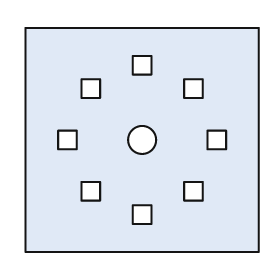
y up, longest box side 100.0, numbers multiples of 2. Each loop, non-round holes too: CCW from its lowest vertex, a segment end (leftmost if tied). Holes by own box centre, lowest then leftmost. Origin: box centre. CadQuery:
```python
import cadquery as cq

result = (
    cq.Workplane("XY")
    .moveTo(-50.0, -48.0)
    .lineTo(50.0, -48.0)
    .lineTo(50.0, 48.0)
    .lineTo(-50.0, 48.0)
    .close()
    .moveTo(-4.0, -36.0)
    .lineTo(4.0, -36.0)
    .lineTo(4.0, -28.0)
    .lineTo(-4.0, -28.0)
    .close()
    .moveTo(-26.0, -26.0)
    .lineTo(-18.0, -26.0)
    .lineTo(-18.0, -18.0)
    .lineTo(-26.0, -18.0)
    .close()
    .moveTo(18.0, -26.0)
    .lineTo(26.0, -26.0)
    .lineTo(26.0, -18.0)
    .lineTo(18.0, -18.0)
    .close()
    .moveTo(-36.0, -4.0)
    .lineTo(-28.0, -4.0)
    .lineTo(-28.0, 4.0)
    .lineTo(-36.0, 4.0)
    .close()
    .moveTo(0.0, 0.0)
    .circle(6.0)
    .moveTo(28.0, -4.0)
    .lineTo(36.0, -4.0)
    .lineTo(36.0, 4.0)
    .lineTo(28.0, 4.0)
    .close()
    .moveTo(-26.0, 18.0)
    .lineTo(-18.0, 18.0)
    .lineTo(-18.0, 26.0)
    .lineTo(-26.0, 26.0)
    .close()
    .moveTo(18.0, 18.0)
    .lineTo(26.0, 18.0)
    .lineTo(26.0, 26.0)
    .lineTo(18.0, 26.0)
    .close()
    .moveTo(-4.0, 28.0)
    .lineTo(4.0, 28.0)
    .lineTo(4.0, 36.0)
    .lineTo(-4.0, 36.0)
    .close()
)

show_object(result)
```